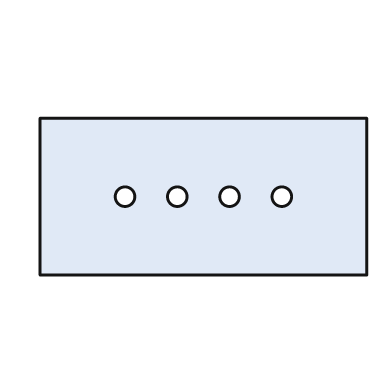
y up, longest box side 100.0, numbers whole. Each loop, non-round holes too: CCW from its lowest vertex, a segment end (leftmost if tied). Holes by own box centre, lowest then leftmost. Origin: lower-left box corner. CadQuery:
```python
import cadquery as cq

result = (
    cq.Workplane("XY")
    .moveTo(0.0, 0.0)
    .lineTo(100.0, 0.0)
    .lineTo(100.0, 48.0)
    .lineTo(0.0, 48.0)
    .close()
    .moveTo(26.0, 24.0)
    .circle(3.0)
    .moveTo(42.0, 24.0)
    .circle(3.0)
    .moveTo(58.0, 24.0)
    .circle(3.0)
    .moveTo(74.0, 24.0)
    .circle(3.0)
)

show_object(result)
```